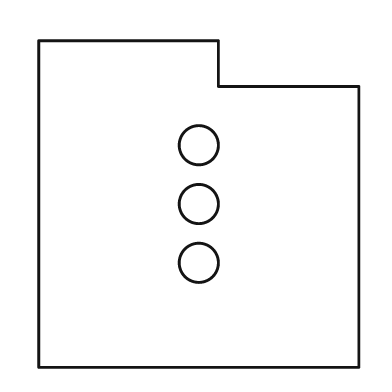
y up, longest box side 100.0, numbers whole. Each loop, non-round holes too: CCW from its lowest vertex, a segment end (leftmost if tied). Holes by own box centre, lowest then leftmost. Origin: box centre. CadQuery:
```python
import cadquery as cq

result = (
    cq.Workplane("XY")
    .moveTo(-49.0, -50.0)
    .lineTo(49.0, -50.0)
    .lineTo(49.0, 36.0)
    .lineTo(6.0, 36.0)
    .lineTo(6.0, 50.0)
    .lineTo(-49.0, 50.0)
    .close()
    .moveTo(0.0, -18.0)
    .circle(6.0)
    .moveTo(0.0, 0.0)
    .circle(6.0)
    .moveTo(0.0, 18.0)
    .circle(6.0)
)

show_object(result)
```